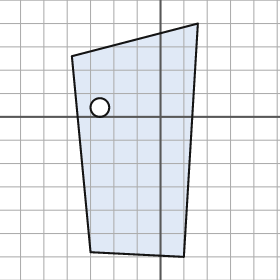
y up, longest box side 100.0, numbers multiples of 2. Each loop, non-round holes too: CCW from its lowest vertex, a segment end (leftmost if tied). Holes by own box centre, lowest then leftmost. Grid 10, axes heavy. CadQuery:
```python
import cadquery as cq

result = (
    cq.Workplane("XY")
    .moveTo(10.0, -60.0)
    .lineTo(16.0, 40.0)
    .lineTo(-38.0, 26.0)
    .lineTo(-30.0, -58.0)
    .close()
    .moveTo(-26.0, 4.0)
    .circle(4.0)
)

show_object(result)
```